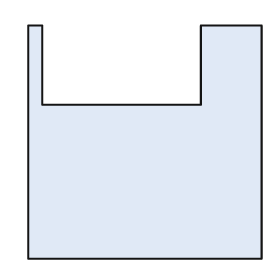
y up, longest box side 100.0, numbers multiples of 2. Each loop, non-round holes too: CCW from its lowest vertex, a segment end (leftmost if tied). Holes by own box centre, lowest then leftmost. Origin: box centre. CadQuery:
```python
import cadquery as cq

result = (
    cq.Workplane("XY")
    .moveTo(-50.0, -50.0)
    .lineTo(50.0, -50.0)
    .lineTo(50.0, 50.0)
    .lineTo(24.0, 50.0)
    .lineTo(24.0, 16.0)
    .lineTo(-44.0, 16.0)
    .lineTo(-44.0, 50.0)
    .lineTo(-50.0, 50.0)
    .close()
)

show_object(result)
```